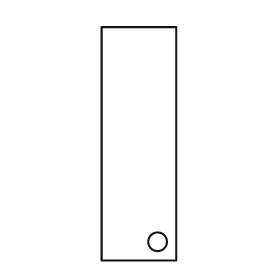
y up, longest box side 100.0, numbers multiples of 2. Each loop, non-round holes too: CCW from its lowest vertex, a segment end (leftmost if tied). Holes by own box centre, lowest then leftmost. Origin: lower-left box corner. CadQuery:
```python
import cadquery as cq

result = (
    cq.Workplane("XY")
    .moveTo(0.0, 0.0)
    .lineTo(32.0, 0.0)
    .lineTo(32.0, 100.0)
    .lineTo(0.0, 100.0)
    .close()
    .moveTo(24.0, 8.0)
    .circle(4.0)
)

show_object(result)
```